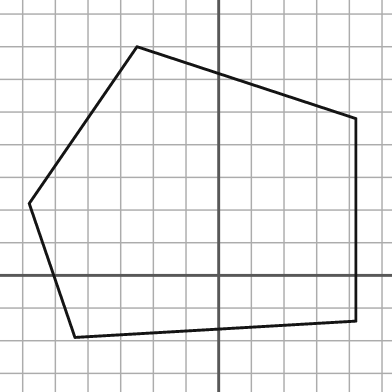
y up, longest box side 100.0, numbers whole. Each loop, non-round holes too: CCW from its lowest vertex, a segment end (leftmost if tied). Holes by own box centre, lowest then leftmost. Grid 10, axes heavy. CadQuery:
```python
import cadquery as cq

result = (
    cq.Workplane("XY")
    .moveTo(-44.0, -19.0)
    .lineTo(42.0, -14.0)
    .lineTo(42.0, 48.0)
    .lineTo(-25.0, 70.0)
    .lineTo(-58.0, 22.0)
    .close()
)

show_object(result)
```